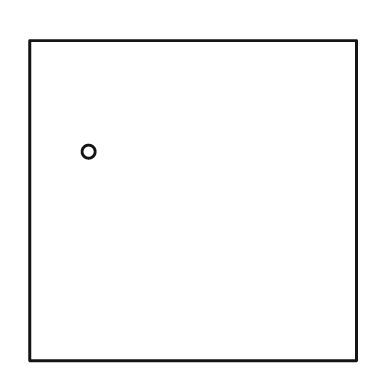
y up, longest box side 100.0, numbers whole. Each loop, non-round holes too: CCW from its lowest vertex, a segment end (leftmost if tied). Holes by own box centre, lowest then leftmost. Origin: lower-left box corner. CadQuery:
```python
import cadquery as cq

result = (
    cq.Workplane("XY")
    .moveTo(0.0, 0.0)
    .lineTo(100.0, 0.0)
    .lineTo(100.0, 98.0)
    .lineTo(0.0, 98.0)
    .close()
    .moveTo(18.0, 64.0)
    .circle(2.0)
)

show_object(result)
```